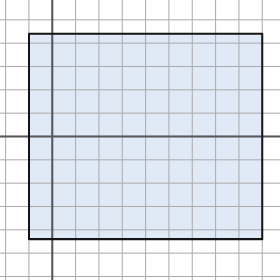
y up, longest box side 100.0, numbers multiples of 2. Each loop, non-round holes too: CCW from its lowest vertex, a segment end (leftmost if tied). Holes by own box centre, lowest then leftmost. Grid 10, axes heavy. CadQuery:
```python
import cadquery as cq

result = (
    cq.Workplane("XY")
    .moveTo(-10.0, -44.0)
    .lineTo(90.0, -44.0)
    .lineTo(90.0, 44.0)
    .lineTo(-10.0, 44.0)
    .close()
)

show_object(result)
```